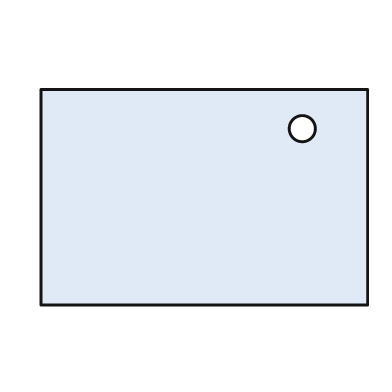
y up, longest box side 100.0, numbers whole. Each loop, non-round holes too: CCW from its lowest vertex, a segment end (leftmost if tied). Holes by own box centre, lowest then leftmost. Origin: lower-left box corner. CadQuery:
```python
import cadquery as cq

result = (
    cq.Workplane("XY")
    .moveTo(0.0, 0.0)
    .lineTo(100.0, 0.0)
    .lineTo(100.0, 66.0)
    .lineTo(0.0, 66.0)
    .close()
    .moveTo(80.0, 54.0)
    .circle(4.0)
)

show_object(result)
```